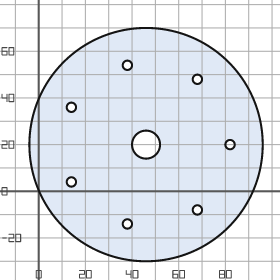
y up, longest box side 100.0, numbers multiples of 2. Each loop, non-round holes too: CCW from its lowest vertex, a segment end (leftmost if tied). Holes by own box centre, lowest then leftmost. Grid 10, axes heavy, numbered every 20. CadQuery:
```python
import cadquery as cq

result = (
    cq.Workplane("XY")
    .moveTo(46.0, 20.0)
    .circle(50.0)
    .moveTo(38.0, -14.0)
    .circle(2.0)
    .moveTo(68.0, -8.0)
    .circle(2.0)
    .moveTo(14.0, 4.0)
    .circle(2.0)
    .moveTo(46.0, 20.0)
    .circle(6.0)
    .moveTo(82.0, 20.0)
    .circle(2.0)
    .moveTo(14.0, 36.0)
    .circle(2.0)
    .moveTo(68.0, 48.0)
    .circle(2.0)
    .moveTo(38.0, 54.0)
    .circle(2.0)
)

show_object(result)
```